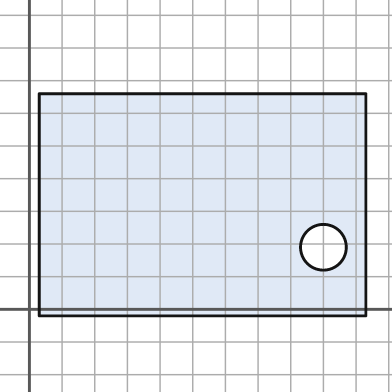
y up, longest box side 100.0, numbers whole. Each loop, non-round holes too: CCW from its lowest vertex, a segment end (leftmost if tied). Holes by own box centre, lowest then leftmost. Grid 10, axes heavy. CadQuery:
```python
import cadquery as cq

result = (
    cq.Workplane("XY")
    .moveTo(3.0, -2.0)
    .lineTo(103.0, -2.0)
    .lineTo(103.0, 66.0)
    .lineTo(3.0, 66.0)
    .close()
    .moveTo(90.0, 19.0)
    .circle(7.0)
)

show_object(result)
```